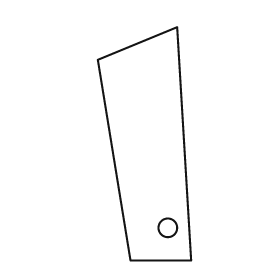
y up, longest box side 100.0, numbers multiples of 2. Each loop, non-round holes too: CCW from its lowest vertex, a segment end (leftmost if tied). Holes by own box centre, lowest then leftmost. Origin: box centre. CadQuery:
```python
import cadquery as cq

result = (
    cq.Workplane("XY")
    .moveTo(-6.0, -50.0)
    .lineTo(20.0, -50.0)
    .lineTo(14.0, 50.0)
    .lineTo(-20.0, 36.0)
    .close()
    .moveTo(10.0, -36.0)
    .circle(4.0)
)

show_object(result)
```